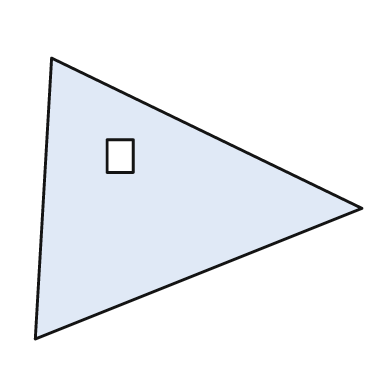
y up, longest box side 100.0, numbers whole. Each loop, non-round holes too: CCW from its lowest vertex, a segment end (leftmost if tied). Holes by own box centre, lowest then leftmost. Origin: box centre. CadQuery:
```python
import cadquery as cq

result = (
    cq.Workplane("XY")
    .moveTo(-50.0, -43.0)
    .lineTo(50.0, -3.0)
    .lineTo(-45.0, 43.0)
    .close()
    .moveTo(-28.0, 8.0)
    .lineTo(-20.0, 8.0)
    .lineTo(-20.0, 18.0)
    .lineTo(-28.0, 18.0)
    .close()
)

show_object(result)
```